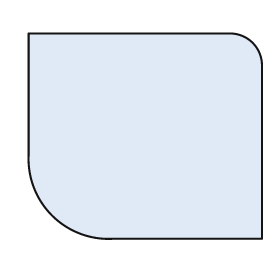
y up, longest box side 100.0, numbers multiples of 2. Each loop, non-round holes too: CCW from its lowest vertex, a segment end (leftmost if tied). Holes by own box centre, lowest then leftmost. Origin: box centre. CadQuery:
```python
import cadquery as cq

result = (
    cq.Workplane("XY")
    .moveTo(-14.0, -44.0)
    .lineTo(50.0, -44.0)
    .lineTo(50.0, 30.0)
    .threePointArc((46.0, 40.0), (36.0, 44.0))
    .lineTo(-50.0, 44.0)
    .lineTo(-50.0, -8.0)
    .threePointArc((-40.0, -34.0), (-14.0, -44.0))
    .close()
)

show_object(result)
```